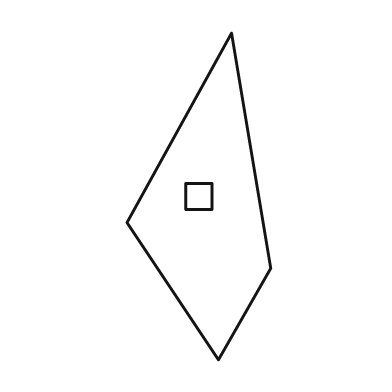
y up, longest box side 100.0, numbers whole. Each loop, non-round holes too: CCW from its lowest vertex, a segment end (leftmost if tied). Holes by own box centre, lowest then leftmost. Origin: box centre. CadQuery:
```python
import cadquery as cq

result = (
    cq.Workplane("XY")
    .moveTo(6.0, -50.0)
    .lineTo(22.0, -22.0)
    .lineTo(10.0, 50.0)
    .lineTo(-22.0, -8.0)
    .close()
    .moveTo(-4.0, -4.0)
    .lineTo(4.0, -4.0)
    .lineTo(4.0, 4.0)
    .lineTo(-4.0, 4.0)
    .close()
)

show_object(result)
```